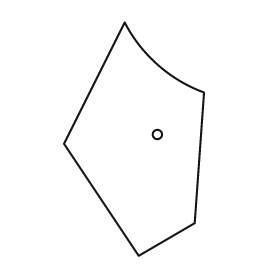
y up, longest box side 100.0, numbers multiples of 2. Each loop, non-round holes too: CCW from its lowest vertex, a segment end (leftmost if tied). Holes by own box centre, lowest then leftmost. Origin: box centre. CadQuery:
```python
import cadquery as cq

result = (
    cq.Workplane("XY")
    .moveTo(2.0, -50.0)
    .lineTo(26.0, -36.0)
    .lineTo(30.0, 20.0)
    .threePointArc((10.0, 32.0), (-4.0, 50.0))
    .lineTo(-30.0, -2.0)
    .close()
    .moveTo(10.0, 2.0)
    .circle(2.0)
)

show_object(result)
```